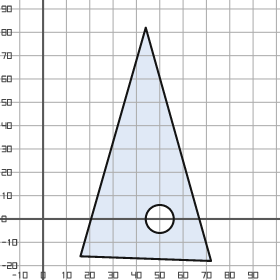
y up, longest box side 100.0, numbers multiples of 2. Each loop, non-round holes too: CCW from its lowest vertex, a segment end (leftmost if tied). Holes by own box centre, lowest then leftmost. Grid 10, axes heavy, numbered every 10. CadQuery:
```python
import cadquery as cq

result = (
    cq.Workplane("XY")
    .moveTo(72.0, -18.0)
    .lineTo(44.0, 82.0)
    .lineTo(16.0, -16.0)
    .close()
    .moveTo(50.0, 0.0)
    .circle(6.0)
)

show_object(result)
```